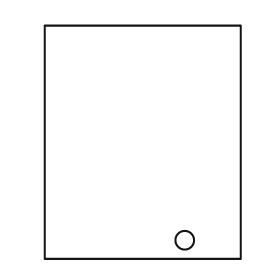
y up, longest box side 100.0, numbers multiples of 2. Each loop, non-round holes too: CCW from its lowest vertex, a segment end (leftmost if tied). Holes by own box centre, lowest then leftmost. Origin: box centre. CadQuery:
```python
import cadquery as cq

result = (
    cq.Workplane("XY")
    .moveTo(-42.0, -50.0)
    .lineTo(42.0, -50.0)
    .lineTo(42.0, 50.0)
    .lineTo(-42.0, 50.0)
    .close()
    .moveTo(18.0, -42.0)
    .circle(4.0)
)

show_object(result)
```